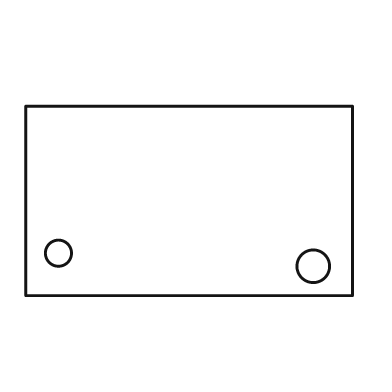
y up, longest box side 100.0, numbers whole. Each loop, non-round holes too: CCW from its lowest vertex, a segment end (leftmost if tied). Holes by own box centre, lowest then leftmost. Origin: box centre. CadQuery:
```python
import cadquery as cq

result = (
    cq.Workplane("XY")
    .moveTo(-50.0, -29.0)
    .lineTo(50.0, -29.0)
    .lineTo(50.0, 29.0)
    .lineTo(-50.0, 29.0)
    .close()
    .moveTo(38.0, -20.0)
    .circle(5.0)
    .moveTo(-40.0, -16.0)
    .circle(4.0)
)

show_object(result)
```